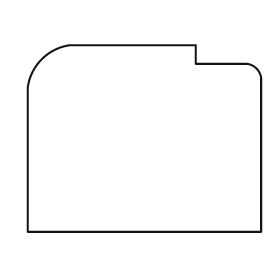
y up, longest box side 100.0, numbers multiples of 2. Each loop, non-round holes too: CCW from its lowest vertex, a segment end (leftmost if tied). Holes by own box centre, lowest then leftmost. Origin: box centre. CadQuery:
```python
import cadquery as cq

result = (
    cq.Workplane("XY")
    .moveTo(-50.0, -40.0)
    .lineTo(50.0, -40.0)
    .lineTo(50.0, 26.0)
    .threePointArc((48.0, 30.0), (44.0, 32.0))
    .lineTo(22.0, 32.0)
    .lineTo(22.0, 40.0)
    .lineTo(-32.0, 40.0)
    .threePointArc((-44.0, 34.0), (-50.0, 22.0))
    .close()
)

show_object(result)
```